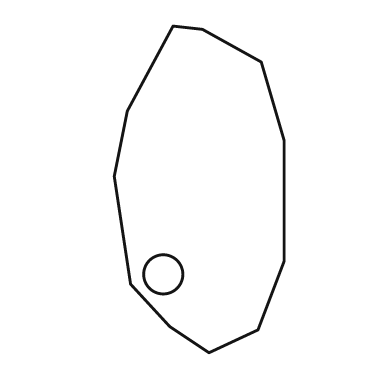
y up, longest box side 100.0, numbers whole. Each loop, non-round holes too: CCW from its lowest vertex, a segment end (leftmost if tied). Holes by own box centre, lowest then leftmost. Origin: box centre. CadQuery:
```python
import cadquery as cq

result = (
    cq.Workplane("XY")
    .moveTo(3.0, -50.0)
    .lineTo(18.0, -43.0)
    .lineTo(26.0, -22.0)
    .lineTo(26.0, 15.0)
    .lineTo(19.0, 39.0)
    .lineTo(1.0, 49.0)
    .lineTo(-8.0, 50.0)
    .lineTo(-22.0, 24.0)
    .lineTo(-26.0, 4.0)
    .lineTo(-21.0, -29.0)
    .lineTo(-9.0, -42.0)
    .close()
    .moveTo(-11.0, -26.0)
    .circle(6.0)
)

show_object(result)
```